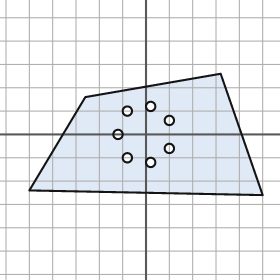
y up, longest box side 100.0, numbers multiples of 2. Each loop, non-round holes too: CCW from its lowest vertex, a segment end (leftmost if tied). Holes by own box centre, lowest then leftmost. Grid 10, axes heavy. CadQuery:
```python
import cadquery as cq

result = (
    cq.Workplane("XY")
    .moveTo(50.0, -26.0)
    .lineTo(32.0, 26.0)
    .lineTo(-26.0, 16.0)
    .lineTo(-50.0, -24.0)
    .close()
    .moveTo(2.0, -12.0)
    .circle(2.0)
    .moveTo(-8.0, -10.0)
    .circle(2.0)
    .moveTo(10.0, -6.0)
    .circle(2.0)
    .moveTo(-12.0, 0.0)
    .circle(2.0)
    .moveTo(10.0, 6.0)
    .circle(2.0)
    .moveTo(-8.0, 10.0)
    .circle(2.0)
    .moveTo(2.0, 12.0)
    .circle(2.0)
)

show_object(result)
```